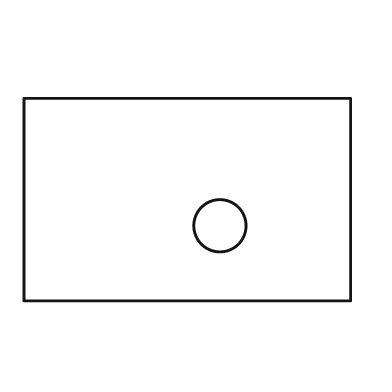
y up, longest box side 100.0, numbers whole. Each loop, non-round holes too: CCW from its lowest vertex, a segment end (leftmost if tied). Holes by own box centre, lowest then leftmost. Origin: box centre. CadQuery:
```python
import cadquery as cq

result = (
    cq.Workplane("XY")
    .moveTo(-50.0, -31.0)
    .lineTo(50.0, -31.0)
    .lineTo(50.0, 31.0)
    .lineTo(-50.0, 31.0)
    .close()
    .moveTo(10.0, -8.0)
    .circle(8.0)
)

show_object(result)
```